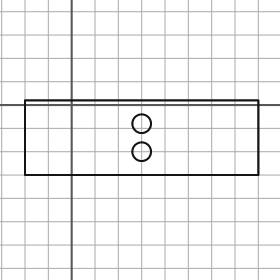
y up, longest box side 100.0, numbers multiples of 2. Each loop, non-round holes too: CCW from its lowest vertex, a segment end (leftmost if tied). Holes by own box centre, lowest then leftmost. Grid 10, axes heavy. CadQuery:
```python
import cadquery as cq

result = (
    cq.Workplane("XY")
    .moveTo(-20.0, -30.0)
    .lineTo(80.0, -30.0)
    .lineTo(80.0, 2.0)
    .lineTo(-20.0, 2.0)
    .close()
    .moveTo(30.0, -20.0)
    .circle(4.0)
    .moveTo(30.0, -8.0)
    .circle(4.0)
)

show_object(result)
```